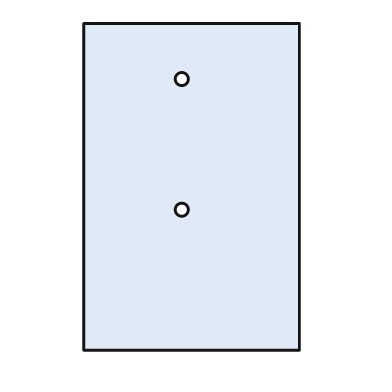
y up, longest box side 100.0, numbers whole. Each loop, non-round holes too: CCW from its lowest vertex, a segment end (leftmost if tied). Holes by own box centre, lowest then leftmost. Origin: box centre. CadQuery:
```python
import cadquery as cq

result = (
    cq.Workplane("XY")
    .moveTo(-33.0, -50.0)
    .lineTo(33.0, -50.0)
    .lineTo(33.0, 50.0)
    .lineTo(-33.0, 50.0)
    .close()
    .moveTo(-3.0, -7.0)
    .circle(2.0)
    .moveTo(-3.0, 33.0)
    .circle(2.0)
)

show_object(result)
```